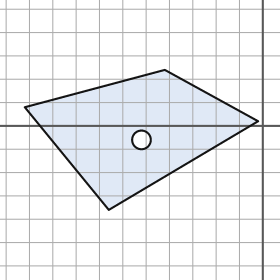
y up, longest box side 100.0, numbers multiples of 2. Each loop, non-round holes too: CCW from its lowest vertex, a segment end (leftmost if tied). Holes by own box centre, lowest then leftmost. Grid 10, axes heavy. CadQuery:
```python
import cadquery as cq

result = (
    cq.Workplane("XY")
    .moveTo(-66.0, -36.0)
    .lineTo(-2.0, 2.0)
    .lineTo(-42.0, 24.0)
    .lineTo(-102.0, 8.0)
    .close()
    .moveTo(-52.0, -6.0)
    .circle(4.0)
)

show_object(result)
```